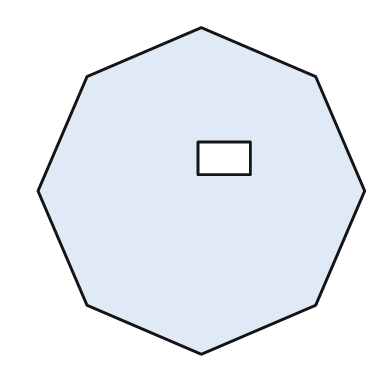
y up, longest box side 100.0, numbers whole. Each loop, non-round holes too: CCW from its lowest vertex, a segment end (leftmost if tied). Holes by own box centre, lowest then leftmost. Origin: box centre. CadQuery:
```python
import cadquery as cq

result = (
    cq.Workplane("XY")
    .moveTo(0.0, -50.0)
    .lineTo(35.0, -35.0)
    .lineTo(50.0, 0.0)
    .lineTo(35.0, 35.0)
    .lineTo(0.0, 50.0)
    .lineTo(-35.0, 35.0)
    .lineTo(-50.0, 0.0)
    .lineTo(-35.0, -35.0)
    .close()
    .moveTo(-1.0, 5.0)
    .lineTo(15.0, 5.0)
    .lineTo(15.0, 15.0)
    .lineTo(-1.0, 15.0)
    .close()
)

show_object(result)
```